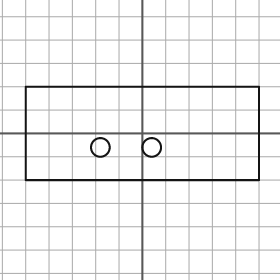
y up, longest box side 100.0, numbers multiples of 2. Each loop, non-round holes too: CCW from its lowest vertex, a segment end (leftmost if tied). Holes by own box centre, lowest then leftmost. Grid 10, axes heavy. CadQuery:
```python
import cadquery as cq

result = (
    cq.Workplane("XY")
    .moveTo(-50.0, -20.0)
    .lineTo(50.0, -20.0)
    .lineTo(50.0, 20.0)
    .lineTo(-50.0, 20.0)
    .close()
    .moveTo(-18.0, -6.0)
    .circle(4.0)
    .moveTo(4.0, -6.0)
    .circle(4.0)
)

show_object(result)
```